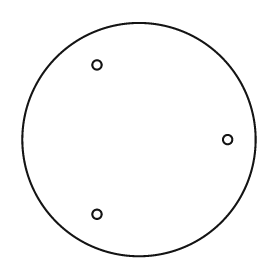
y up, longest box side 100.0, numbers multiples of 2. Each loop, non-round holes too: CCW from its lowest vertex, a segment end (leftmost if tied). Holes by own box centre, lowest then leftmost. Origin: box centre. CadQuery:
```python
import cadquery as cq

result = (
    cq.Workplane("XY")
    .moveTo(0.0, 0.0)
    .circle(50.0)
    .moveTo(-18.0, -32.0)
    .circle(2.0)
    .moveTo(38.0, 0.0)
    .circle(2.0)
    .moveTo(-18.0, 32.0)
    .circle(2.0)
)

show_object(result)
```